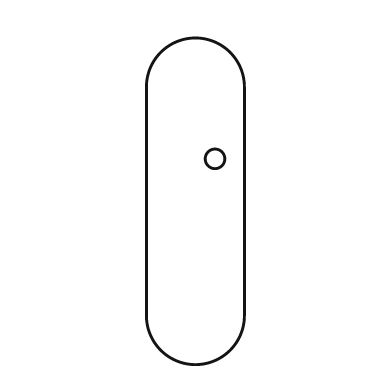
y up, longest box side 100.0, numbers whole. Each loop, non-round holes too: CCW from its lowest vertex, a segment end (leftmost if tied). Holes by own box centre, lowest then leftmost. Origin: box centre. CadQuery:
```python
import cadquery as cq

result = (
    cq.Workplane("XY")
    .moveTo(-15.0, -35.0)
    .threePointArc((0.0, -50.0), (15.0, -35.0))
    .lineTo(15.0, 35.0)
    .threePointArc((0.0, 50.0), (-15.0, 35.0))
    .close()
    .moveTo(6.0, 13.0)
    .circle(3.0)
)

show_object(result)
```